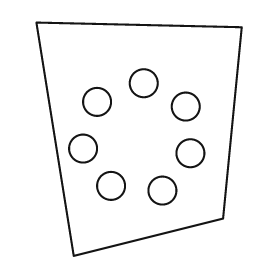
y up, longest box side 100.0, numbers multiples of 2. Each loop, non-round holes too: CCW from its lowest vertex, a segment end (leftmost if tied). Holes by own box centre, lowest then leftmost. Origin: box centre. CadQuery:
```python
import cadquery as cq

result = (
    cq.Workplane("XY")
    .moveTo(-28.0, -50.0)
    .lineTo(36.0, -34.0)
    .lineTo(44.0, 48.0)
    .lineTo(-44.0, 50.0)
    .close()
    .moveTo(10.0, -22.0)
    .circle(6.0)
    .moveTo(-12.0, -20.0)
    .circle(6.0)
    .moveTo(22.0, -6.0)
    .circle(6.0)
    .moveTo(-24.0, -4.0)
    .circle(6.0)
    .moveTo(20.0, 14.0)
    .circle(6.0)
    .moveTo(-18.0, 16.0)
    .circle(6.0)
    .moveTo(2.0, 24.0)
    .circle(6.0)
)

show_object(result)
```